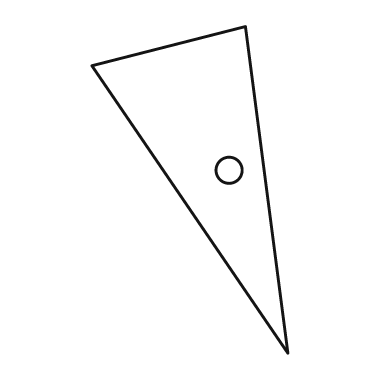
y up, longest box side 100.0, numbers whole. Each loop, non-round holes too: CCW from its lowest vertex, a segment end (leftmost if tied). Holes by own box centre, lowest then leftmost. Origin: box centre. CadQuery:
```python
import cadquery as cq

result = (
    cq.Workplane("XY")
    .moveTo(30.0, -50.0)
    .lineTo(17.0, 50.0)
    .lineTo(-30.0, 38.0)
    .close()
    .moveTo(12.0, 6.0)
    .circle(4.0)
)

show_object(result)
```